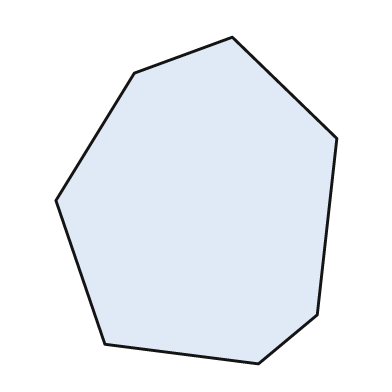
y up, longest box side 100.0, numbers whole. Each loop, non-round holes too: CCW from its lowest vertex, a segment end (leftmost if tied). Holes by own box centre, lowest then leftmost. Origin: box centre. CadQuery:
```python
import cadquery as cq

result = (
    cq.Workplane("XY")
    .moveTo(19.0, -50.0)
    .lineTo(37.0, -35.0)
    .lineTo(43.0, 19.0)
    .lineTo(11.0, 50.0)
    .lineTo(-19.0, 39.0)
    .lineTo(-43.0, 0.0)
    .lineTo(-28.0, -44.0)
    .close()
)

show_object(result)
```